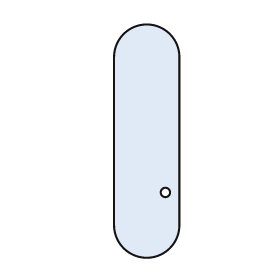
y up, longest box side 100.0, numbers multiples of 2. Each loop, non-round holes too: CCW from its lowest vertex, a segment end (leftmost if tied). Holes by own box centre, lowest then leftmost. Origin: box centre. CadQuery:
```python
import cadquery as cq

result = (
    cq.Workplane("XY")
    .moveTo(-14.0, -36.0)
    .threePointArc((0.0, -50.0), (14.0, -36.0))
    .lineTo(14.0, 36.0)
    .threePointArc((0.0, 50.0), (-14.0, 36.0))
    .close()
    .moveTo(8.0, -22.0)
    .circle(2.0)
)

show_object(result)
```